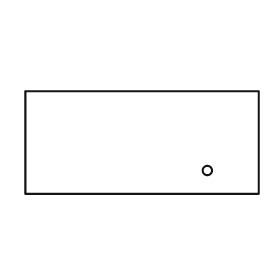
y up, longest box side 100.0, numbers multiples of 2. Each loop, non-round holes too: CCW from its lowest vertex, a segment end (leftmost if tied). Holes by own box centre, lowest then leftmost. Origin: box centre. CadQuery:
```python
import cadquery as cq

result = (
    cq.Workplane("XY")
    .moveTo(-50.0, -22.0)
    .lineTo(50.0, -22.0)
    .lineTo(50.0, 22.0)
    .lineTo(-50.0, 22.0)
    .close()
    .moveTo(28.0, -12.0)
    .circle(2.0)
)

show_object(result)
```